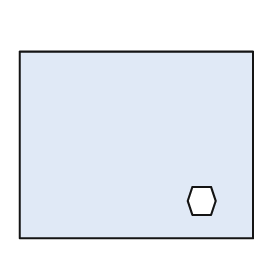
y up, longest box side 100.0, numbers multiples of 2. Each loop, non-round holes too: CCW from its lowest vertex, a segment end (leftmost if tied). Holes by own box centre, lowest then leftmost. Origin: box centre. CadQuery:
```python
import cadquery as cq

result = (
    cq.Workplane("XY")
    .moveTo(-50.0, -40.0)
    .lineTo(50.0, -40.0)
    .lineTo(50.0, 40.0)
    .lineTo(-50.0, 40.0)
    .close()
    .moveTo(24.0, -30.0)
    .lineTo(32.0, -30.0)
    .lineTo(34.0, -24.0)
    .lineTo(32.0, -18.0)
    .lineTo(24.0, -18.0)
    .lineTo(22.0, -24.0)
    .close()
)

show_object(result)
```